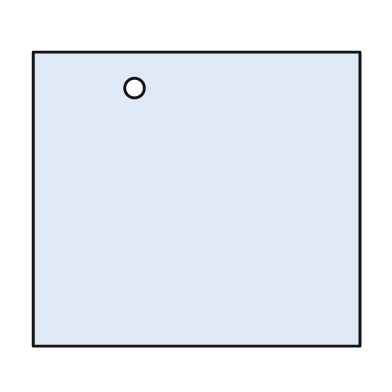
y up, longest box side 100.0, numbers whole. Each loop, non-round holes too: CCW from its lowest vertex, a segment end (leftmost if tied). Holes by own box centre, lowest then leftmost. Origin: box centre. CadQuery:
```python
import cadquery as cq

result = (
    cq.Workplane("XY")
    .moveTo(-50.0, -45.0)
    .lineTo(50.0, -45.0)
    .lineTo(50.0, 45.0)
    .lineTo(-50.0, 45.0)
    .close()
    .moveTo(-19.0, 34.0)
    .circle(3.0)
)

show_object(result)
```